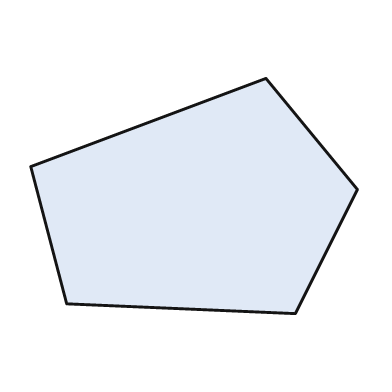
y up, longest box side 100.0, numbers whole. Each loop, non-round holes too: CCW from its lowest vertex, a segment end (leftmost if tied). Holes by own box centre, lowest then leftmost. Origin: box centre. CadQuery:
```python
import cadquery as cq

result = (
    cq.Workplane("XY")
    .moveTo(31.0, -36.0)
    .lineTo(50.0, 2.0)
    .lineTo(22.0, 36.0)
    .lineTo(-50.0, 9.0)
    .lineTo(-39.0, -33.0)
    .close()
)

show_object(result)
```